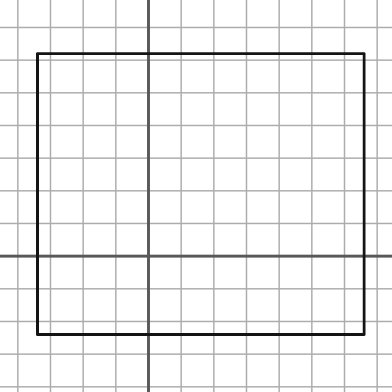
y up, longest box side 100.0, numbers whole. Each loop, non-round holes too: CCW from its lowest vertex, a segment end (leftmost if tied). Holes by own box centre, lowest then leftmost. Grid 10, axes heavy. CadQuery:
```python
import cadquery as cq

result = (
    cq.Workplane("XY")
    .moveTo(-34.0, -24.0)
    .lineTo(66.0, -24.0)
    .lineTo(66.0, 62.0)
    .lineTo(-34.0, 62.0)
    .close()
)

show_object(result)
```